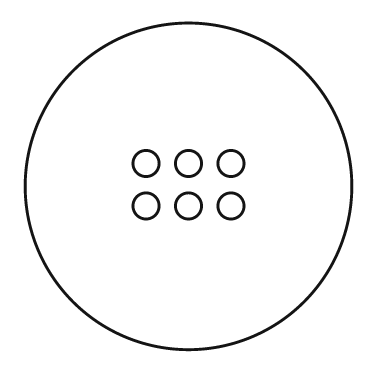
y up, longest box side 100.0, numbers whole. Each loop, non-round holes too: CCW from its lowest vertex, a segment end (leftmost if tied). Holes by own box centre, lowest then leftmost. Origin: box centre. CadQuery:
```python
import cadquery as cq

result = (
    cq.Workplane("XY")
    .moveTo(0.0, 0.0)
    .circle(50.0)
    .moveTo(-13.0, -6.0)
    .circle(4.0)
    .moveTo(0.0, -6.0)
    .circle(4.0)
    .moveTo(13.0, -6.0)
    .circle(4.0)
    .moveTo(-13.0, 7.0)
    .circle(4.0)
    .moveTo(0.0, 7.0)
    .circle(4.0)
    .moveTo(13.0, 7.0)
    .circle(4.0)
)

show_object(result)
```